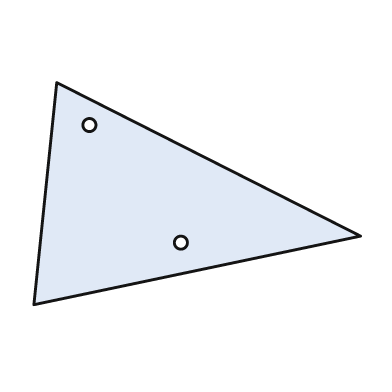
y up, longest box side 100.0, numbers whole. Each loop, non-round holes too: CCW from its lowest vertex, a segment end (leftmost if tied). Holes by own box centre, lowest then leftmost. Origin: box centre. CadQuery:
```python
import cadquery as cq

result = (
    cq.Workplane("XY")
    .moveTo(-50.0, -34.0)
    .lineTo(50.0, -13.0)
    .lineTo(-43.0, 34.0)
    .close()
    .moveTo(-5.0, -15.0)
    .circle(2.0)
    .moveTo(-33.0, 21.0)
    .circle(2.0)
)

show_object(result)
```